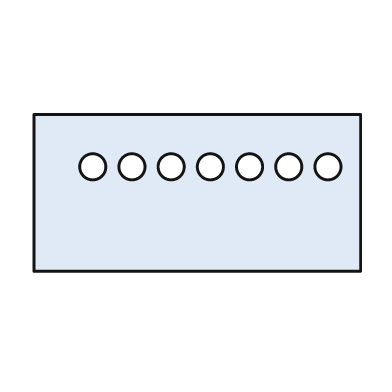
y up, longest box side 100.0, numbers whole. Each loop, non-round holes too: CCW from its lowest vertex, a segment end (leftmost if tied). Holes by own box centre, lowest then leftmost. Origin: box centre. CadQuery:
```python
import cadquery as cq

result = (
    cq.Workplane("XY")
    .moveTo(-50.0, -24.0)
    .lineTo(50.0, -24.0)
    .lineTo(50.0, 24.0)
    .lineTo(-50.0, 24.0)
    .close()
    .moveTo(-32.0, 8.0)
    .circle(4.0)
    .moveTo(-20.0, 8.0)
    .circle(4.0)
    .moveTo(-8.0, 8.0)
    .circle(4.0)
    .moveTo(4.0, 8.0)
    .circle(4.0)
    .moveTo(16.0, 8.0)
    .circle(4.0)
    .moveTo(28.0, 8.0)
    .circle(4.0)
    .moveTo(40.0, 8.0)
    .circle(4.0)
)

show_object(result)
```